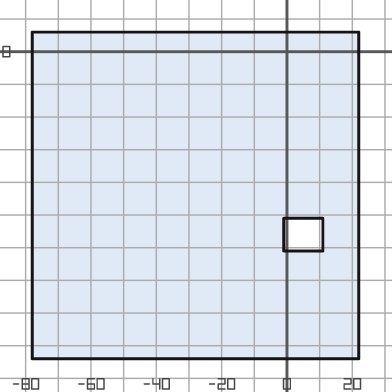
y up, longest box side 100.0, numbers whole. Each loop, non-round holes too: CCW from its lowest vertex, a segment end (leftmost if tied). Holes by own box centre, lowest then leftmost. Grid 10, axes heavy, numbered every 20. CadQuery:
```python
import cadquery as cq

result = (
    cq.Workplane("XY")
    .moveTo(-78.0, -94.0)
    .lineTo(22.0, -94.0)
    .lineTo(22.0, 6.0)
    .lineTo(-78.0, 6.0)
    .close()
    .moveTo(-1.0, -61.0)
    .lineTo(11.0, -61.0)
    .lineTo(11.0, -51.0)
    .lineTo(-1.0, -51.0)
    .close()
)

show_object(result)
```